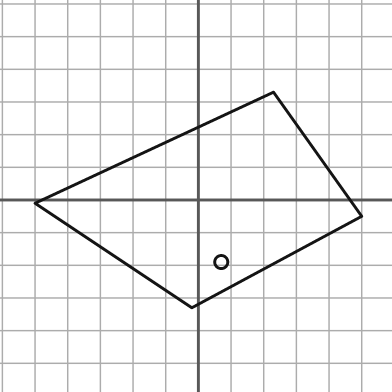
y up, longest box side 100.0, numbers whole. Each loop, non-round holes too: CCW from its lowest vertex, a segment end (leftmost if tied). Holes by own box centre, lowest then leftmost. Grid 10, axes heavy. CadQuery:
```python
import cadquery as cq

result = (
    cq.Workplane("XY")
    .moveTo(-2.0, -33.0)
    .lineTo(50.0, -5.0)
    .lineTo(23.0, 33.0)
    .lineTo(-50.0, -1.0)
    .close()
    .moveTo(7.0, -19.0)
    .circle(2.0)
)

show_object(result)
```